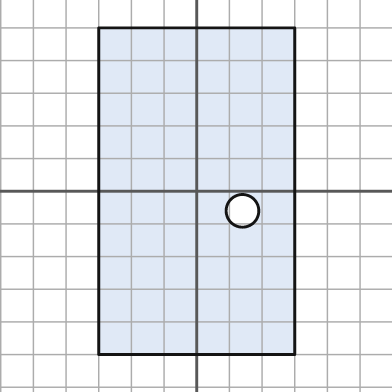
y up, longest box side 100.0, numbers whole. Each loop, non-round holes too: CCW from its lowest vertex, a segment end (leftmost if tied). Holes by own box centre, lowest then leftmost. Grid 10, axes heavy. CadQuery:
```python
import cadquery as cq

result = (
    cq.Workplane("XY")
    .moveTo(-30.0, -50.0)
    .lineTo(30.0, -50.0)
    .lineTo(30.0, 50.0)
    .lineTo(-30.0, 50.0)
    .close()
    .moveTo(14.0, -6.0)
    .circle(5.0)
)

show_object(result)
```